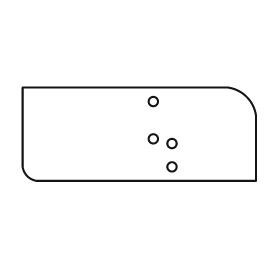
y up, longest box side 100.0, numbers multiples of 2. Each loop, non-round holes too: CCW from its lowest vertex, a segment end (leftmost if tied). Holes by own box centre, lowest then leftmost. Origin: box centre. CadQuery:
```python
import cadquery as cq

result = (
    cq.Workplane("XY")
    .moveTo(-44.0, -20.0)
    .lineTo(50.0, -20.0)
    .lineTo(50.0, 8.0)
    .threePointArc((46.0, 16.0), (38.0, 20.0))
    .lineTo(-50.0, 20.0)
    .lineTo(-50.0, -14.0)
    .threePointArc((-48.0, -18.0), (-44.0, -20.0))
    .close()
    .moveTo(14.0, -14.0)
    .circle(2.0)
    .moveTo(14.0, -4.0)
    .circle(2.0)
    .moveTo(6.0, -2.0)
    .circle(2.0)
    .moveTo(6.0, 14.0)
    .circle(2.0)
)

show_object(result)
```